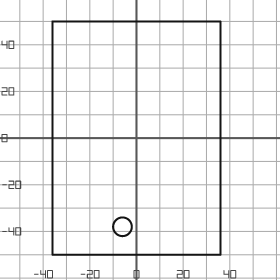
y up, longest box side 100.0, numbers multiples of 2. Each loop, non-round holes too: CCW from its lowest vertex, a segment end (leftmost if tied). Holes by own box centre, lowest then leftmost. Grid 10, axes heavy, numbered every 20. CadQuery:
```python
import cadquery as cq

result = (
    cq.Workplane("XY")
    .moveTo(-36.0, -50.0)
    .lineTo(36.0, -50.0)
    .lineTo(36.0, 50.0)
    .lineTo(-36.0, 50.0)
    .close()
    .moveTo(-6.0, -38.0)
    .circle(4.0)
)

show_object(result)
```